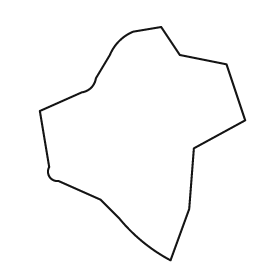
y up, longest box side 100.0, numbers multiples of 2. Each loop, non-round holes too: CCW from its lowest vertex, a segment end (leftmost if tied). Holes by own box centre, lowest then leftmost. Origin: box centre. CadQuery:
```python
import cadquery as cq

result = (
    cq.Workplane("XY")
    .moveTo(12.0, -50.0)
    .lineTo(20.0, -28.0)
    .lineTo(22.0, -2.0)
    .lineTo(44.0, 10.0)
    .lineTo(36.0, 34.0)
    .lineTo(16.0, 38.0)
    .lineTo(8.0, 50.0)
    .lineTo(-4.0, 48.0)
    .threePointArc((-10.0, 44.0), (-14.0, 38.0))
    .lineTo(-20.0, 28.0)
    .threePointArc((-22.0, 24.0), (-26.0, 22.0))
    .lineTo(-44.0, 14.0)
    .lineTo(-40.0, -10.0)
    .threePointArc((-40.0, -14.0), (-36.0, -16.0))
    .lineTo(-18.0, -24.0)
    .lineTo(-10.0, -32.0)
    .threePointArc((0.0, -42.0), (12.0, -50.0))
    .close()
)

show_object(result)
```